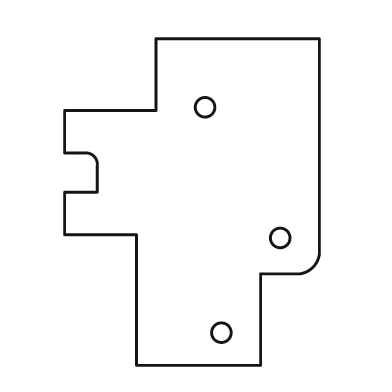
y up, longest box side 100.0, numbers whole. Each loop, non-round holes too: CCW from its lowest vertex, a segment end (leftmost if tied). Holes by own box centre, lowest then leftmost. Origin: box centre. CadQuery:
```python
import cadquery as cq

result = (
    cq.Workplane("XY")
    .moveTo(-17.0, -50.0)
    .lineTo(21.0, -50.0)
    .lineTo(21.0, -22.0)
    .lineTo(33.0, -22.0)
    .threePointArc((37.0, -20.0), (39.0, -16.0))
    .lineTo(39.0, 50.0)
    .lineTo(-11.0, 50.0)
    .lineTo(-11.0, 28.0)
    .lineTo(-39.0, 28.0)
    .lineTo(-39.0, 15.0)
    .lineTo(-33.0, 15.0)
    .threePointArc((-30.0, 14.0), (-29.0, 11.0))
    .lineTo(-29.0, 3.0)
    .lineTo(-39.0, 3.0)
    .lineTo(-39.0, -10.0)
    .lineTo(-17.0, -10.0)
    .close()
    .moveTo(9.0, -40.0)
    .circle(3.0)
    .moveTo(27.0, -11.0)
    .circle(3.0)
    .moveTo(4.0, 29.0)
    .circle(3.0)
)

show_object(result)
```